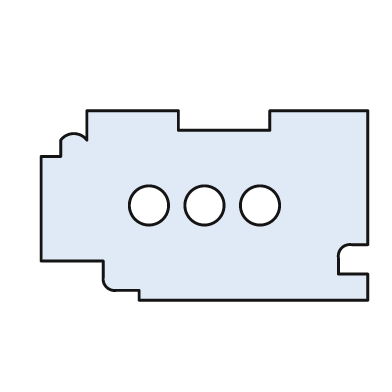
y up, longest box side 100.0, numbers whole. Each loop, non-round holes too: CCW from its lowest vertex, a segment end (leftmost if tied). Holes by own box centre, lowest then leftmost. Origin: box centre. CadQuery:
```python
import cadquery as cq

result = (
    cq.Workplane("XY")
    .moveTo(-20.0, -29.0)
    .lineTo(50.0, -29.0)
    .lineTo(50.0, -21.0)
    .lineTo(41.0, -21.0)
    .lineTo(41.0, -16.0)
    .threePointArc((42.0, -13.0), (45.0, -12.0))
    .lineTo(50.0, -12.0)
    .lineTo(50.0, 29.0)
    .lineTo(20.0, 29.0)
    .lineTo(20.0, 23.0)
    .lineTo(-8.0, 23.0)
    .lineTo(-8.0, 29.0)
    .lineTo(-36.0, 29.0)
    .lineTo(-36.0, 20.0)
    .threePointArc((-40.0, 22.0), (-44.0, 20.0))
    .lineTo(-44.0, 15.0)
    .lineTo(-50.0, 15.0)
    .lineTo(-50.0, -17.0)
    .lineTo(-31.0, -17.0)
    .lineTo(-31.0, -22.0)
    .threePointArc((-30.0, -25.0), (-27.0, -26.0))
    .lineTo(-20.0, -26.0)
    .close()
    .moveTo(-17.0, 0.0)
    .circle(6.0)
    .moveTo(0.0, 0.0)
    .circle(6.0)
    .moveTo(17.0, 0.0)
    .circle(6.0)
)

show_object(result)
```